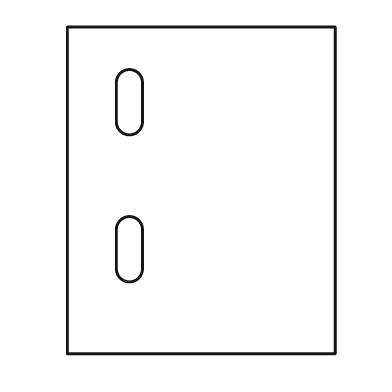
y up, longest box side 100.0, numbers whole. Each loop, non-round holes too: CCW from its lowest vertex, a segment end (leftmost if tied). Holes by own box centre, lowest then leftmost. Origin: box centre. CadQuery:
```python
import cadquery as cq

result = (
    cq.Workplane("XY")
    .moveTo(-41.0, -50.0)
    .lineTo(41.0, -50.0)
    .lineTo(41.0, 50.0)
    .lineTo(-41.0, 50.0)
    .close()
    .moveTo(-26.0, -24.0)
    .threePointArc((-22.0, -28.0), (-18.0, -24.0))
    .lineTo(-18.0, -12.0)
    .threePointArc((-22.0, -8.0), (-26.0, -12.0))
    .close()
    .moveTo(-26.0, 21.0)
    .threePointArc((-22.0, 17.0), (-18.0, 21.0))
    .lineTo(-18.0, 33.0)
    .threePointArc((-22.0, 37.0), (-26.0, 33.0))
    .close()
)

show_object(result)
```